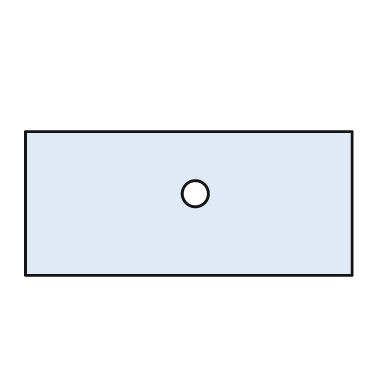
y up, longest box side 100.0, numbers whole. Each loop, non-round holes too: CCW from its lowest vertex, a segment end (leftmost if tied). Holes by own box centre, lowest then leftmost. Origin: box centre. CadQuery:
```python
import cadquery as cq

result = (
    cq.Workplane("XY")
    .moveTo(-50.0, -22.0)
    .lineTo(50.0, -22.0)
    .lineTo(50.0, 22.0)
    .lineTo(-50.0, 22.0)
    .close()
    .moveTo(2.0, 3.0)
    .circle(4.0)
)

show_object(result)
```